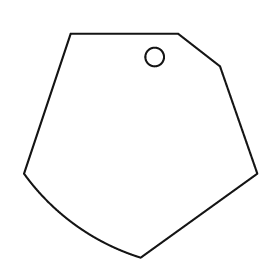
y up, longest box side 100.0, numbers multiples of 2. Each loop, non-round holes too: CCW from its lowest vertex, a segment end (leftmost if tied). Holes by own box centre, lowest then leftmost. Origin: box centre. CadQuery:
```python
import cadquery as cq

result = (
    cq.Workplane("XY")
    .moveTo(0.0, -48.0)
    .lineTo(50.0, -12.0)
    .lineTo(34.0, 34.0)
    .lineTo(16.0, 48.0)
    .lineTo(-30.0, 48.0)
    .lineTo(-50.0, -12.0)
    .threePointArc((-28.0, -34.0), (0.0, -48.0))
    .close()
    .moveTo(6.0, 38.0)
    .circle(4.0)
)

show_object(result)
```